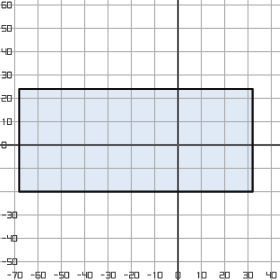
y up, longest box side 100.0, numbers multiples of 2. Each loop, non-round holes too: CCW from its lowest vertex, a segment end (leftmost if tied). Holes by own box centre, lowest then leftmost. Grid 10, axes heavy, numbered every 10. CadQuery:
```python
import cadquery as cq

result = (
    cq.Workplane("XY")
    .moveTo(-68.0, -20.0)
    .lineTo(32.0, -20.0)
    .lineTo(32.0, 24.0)
    .lineTo(-68.0, 24.0)
    .close()
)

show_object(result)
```